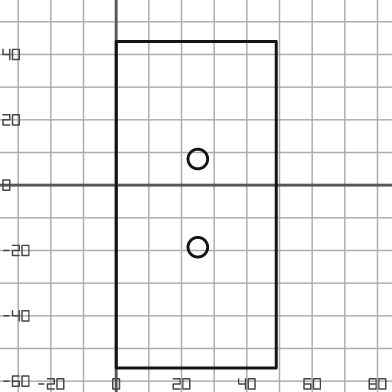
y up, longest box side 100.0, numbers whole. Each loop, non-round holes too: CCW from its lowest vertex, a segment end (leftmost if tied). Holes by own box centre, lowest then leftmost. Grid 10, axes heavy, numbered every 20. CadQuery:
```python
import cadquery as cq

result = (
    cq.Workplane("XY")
    .moveTo(0.0, -56.0)
    .lineTo(49.0, -56.0)
    .lineTo(49.0, 44.0)
    .lineTo(0.0, 44.0)
    .close()
    .moveTo(25.0, -19.0)
    .circle(3.0)
    .moveTo(25.0, 8.0)
    .circle(3.0)
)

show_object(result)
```